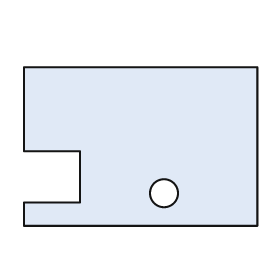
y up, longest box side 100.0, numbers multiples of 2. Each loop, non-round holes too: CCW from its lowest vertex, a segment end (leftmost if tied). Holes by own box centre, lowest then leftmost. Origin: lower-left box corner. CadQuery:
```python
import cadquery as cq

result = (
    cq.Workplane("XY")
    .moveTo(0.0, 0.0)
    .lineTo(100.0, 0.0)
    .lineTo(100.0, 68.0)
    .lineTo(0.0, 68.0)
    .lineTo(0.0, 32.0)
    .lineTo(24.0, 32.0)
    .lineTo(24.0, 10.0)
    .lineTo(0.0, 10.0)
    .close()
    .moveTo(60.0, 14.0)
    .circle(6.0)
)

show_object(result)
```